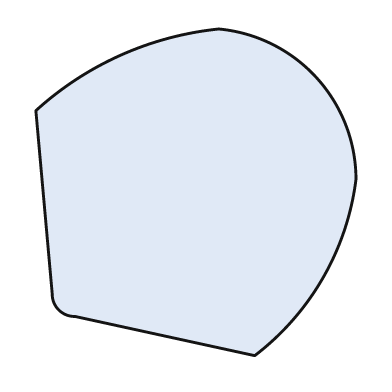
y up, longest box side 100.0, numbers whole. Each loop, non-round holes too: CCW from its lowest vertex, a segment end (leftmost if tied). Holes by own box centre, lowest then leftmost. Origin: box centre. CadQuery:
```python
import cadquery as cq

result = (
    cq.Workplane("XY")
    .moveTo(18.0, -50.0)
    .threePointArc((39.0, -26.0), (49.0, 4.0))
    .threePointArc((37.0, 35.0), (7.0, 50.0))
    .threePointArc((-23.0, 42.0), (-49.0, 25.0))
    .lineTo(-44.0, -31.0)
    .threePointArc((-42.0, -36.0), (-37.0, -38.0))
    .close()
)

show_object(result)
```